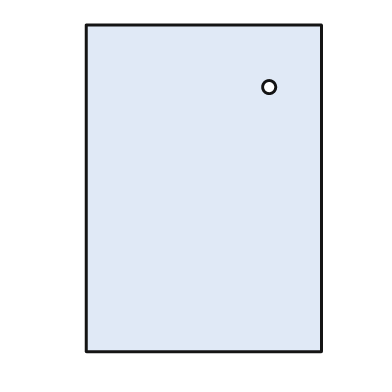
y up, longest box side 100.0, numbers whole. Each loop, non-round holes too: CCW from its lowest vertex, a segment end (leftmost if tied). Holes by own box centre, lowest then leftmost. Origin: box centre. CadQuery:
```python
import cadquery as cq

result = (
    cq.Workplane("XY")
    .moveTo(-36.0, -50.0)
    .lineTo(36.0, -50.0)
    .lineTo(36.0, 50.0)
    .lineTo(-36.0, 50.0)
    .close()
    .moveTo(20.0, 31.0)
    .circle(2.0)
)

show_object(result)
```